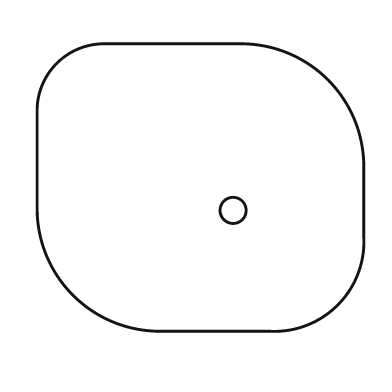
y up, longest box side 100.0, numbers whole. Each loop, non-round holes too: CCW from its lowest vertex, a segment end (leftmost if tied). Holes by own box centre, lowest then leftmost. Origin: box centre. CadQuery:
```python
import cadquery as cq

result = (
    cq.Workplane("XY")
    .moveTo(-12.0, -44.0)
    .lineTo(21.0, -44.0)
    .threePointArc((42.0, -36.0), (50.0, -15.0))
    .lineTo(50.0, 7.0)
    .threePointArc((39.0, 33.0), (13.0, 44.0))
    .lineTo(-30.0, 44.0)
    .threePointArc((-44.0, 38.0), (-50.0, 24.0))
    .lineTo(-50.0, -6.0)
    .threePointArc((-39.0, -33.0), (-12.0, -44.0))
    .close()
    .moveTo(10.0, -7.0)
    .circle(4.0)
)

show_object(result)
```